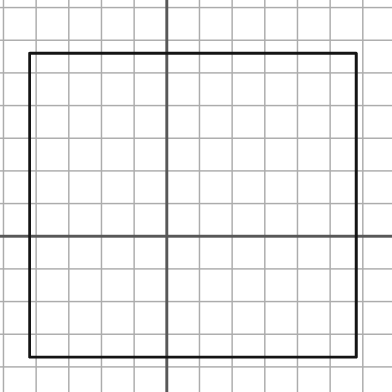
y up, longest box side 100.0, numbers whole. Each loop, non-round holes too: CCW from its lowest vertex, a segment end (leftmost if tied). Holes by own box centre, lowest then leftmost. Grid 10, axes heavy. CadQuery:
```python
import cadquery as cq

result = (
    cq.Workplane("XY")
    .moveTo(-42.0, -37.0)
    .lineTo(58.0, -37.0)
    .lineTo(58.0, 56.0)
    .lineTo(-42.0, 56.0)
    .close()
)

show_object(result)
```